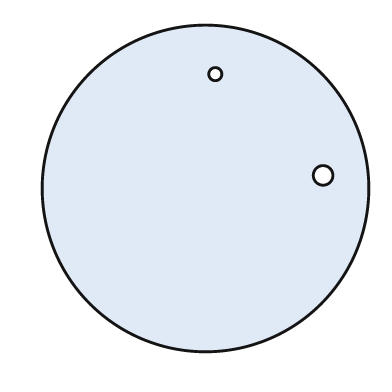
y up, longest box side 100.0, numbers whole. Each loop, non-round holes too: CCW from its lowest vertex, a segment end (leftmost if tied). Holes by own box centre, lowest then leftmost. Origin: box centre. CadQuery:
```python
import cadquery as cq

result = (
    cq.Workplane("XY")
    .moveTo(0.0, 0.0)
    .circle(50.0)
    .moveTo(36.0, 4.0)
    .circle(3.0)
    .moveTo(3.0, 35.0)
    .circle(2.0)
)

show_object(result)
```